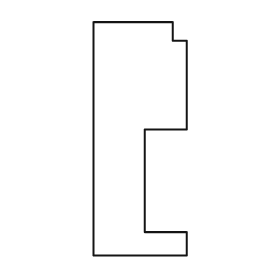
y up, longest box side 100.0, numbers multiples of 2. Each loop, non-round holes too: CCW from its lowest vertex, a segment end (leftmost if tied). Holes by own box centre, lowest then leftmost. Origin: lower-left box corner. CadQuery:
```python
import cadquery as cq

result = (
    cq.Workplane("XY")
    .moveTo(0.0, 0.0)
    .lineTo(40.0, 0.0)
    .lineTo(40.0, 10.0)
    .lineTo(22.0, 10.0)
    .lineTo(22.0, 54.0)
    .lineTo(40.0, 54.0)
    .lineTo(40.0, 92.0)
    .lineTo(34.0, 92.0)
    .lineTo(34.0, 100.0)
    .lineTo(0.0, 100.0)
    .close()
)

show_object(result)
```